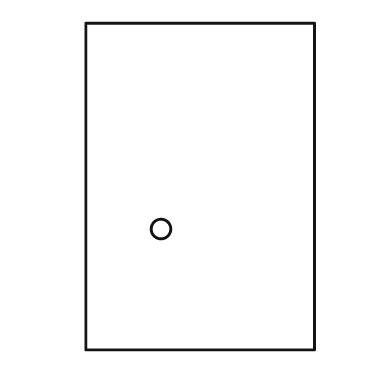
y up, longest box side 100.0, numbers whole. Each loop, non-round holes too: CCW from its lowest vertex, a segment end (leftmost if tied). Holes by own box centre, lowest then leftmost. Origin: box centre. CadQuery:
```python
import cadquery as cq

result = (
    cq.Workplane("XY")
    .moveTo(-35.0, -50.0)
    .lineTo(35.0, -50.0)
    .lineTo(35.0, 50.0)
    .lineTo(-35.0, 50.0)
    .close()
    .moveTo(-12.0, -13.0)
    .circle(3.0)
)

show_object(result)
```